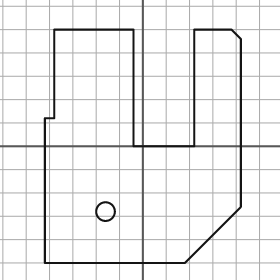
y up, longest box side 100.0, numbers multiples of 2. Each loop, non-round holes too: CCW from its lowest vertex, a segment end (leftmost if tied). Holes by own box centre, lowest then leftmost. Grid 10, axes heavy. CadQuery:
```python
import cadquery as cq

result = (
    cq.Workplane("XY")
    .moveTo(-42.0, -50.0)
    .lineTo(18.0, -50.0)
    .lineTo(42.0, -26.0)
    .lineTo(42.0, 46.0)
    .lineTo(38.0, 50.0)
    .lineTo(22.0, 50.0)
    .lineTo(22.0, 0.0)
    .lineTo(-4.0, 0.0)
    .lineTo(-4.0, 50.0)
    .lineTo(-38.0, 50.0)
    .lineTo(-38.0, 12.0)
    .lineTo(-42.0, 12.0)
    .close()
    .moveTo(-16.0, -28.0)
    .circle(4.0)
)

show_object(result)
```